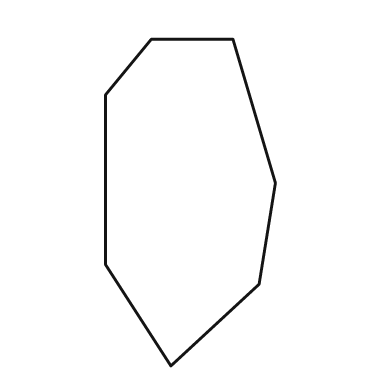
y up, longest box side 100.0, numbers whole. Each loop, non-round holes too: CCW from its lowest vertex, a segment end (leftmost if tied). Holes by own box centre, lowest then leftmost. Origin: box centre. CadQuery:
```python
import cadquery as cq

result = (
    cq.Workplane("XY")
    .moveTo(-6.0, -50.0)
    .lineTo(21.0, -25.0)
    .lineTo(26.0, 6.0)
    .lineTo(13.0, 50.0)
    .lineTo(-12.0, 50.0)
    .lineTo(-26.0, 33.0)
    .lineTo(-26.0, -19.0)
    .close()
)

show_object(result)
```